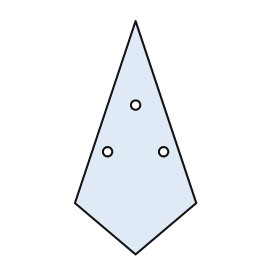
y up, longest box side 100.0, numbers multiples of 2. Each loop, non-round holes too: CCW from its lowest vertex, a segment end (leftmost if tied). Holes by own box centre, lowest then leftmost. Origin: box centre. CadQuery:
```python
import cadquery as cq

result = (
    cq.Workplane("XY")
    .moveTo(0.0, -50.0)
    .lineTo(26.0, -28.0)
    .lineTo(0.0, 50.0)
    .lineTo(-26.0, -28.0)
    .close()
    .moveTo(-12.0, -6.0)
    .circle(2.0)
    .moveTo(12.0, -6.0)
    .circle(2.0)
    .moveTo(0.0, 14.0)
    .circle(2.0)
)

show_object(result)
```